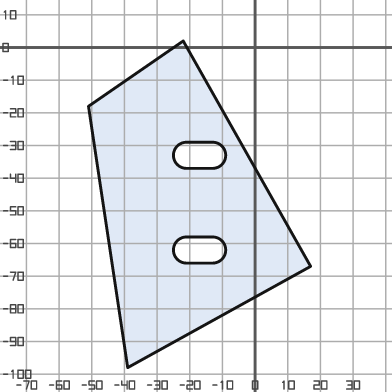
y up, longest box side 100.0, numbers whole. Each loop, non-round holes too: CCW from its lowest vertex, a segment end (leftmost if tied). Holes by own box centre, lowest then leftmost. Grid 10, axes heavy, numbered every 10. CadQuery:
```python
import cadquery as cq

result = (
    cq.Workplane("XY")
    .moveTo(-39.0, -98.0)
    .lineTo(17.0, -67.0)
    .lineTo(-22.0, 2.0)
    .lineTo(-51.0, -18.0)
    .close()
    .moveTo(-21.0, -66.0)
    .lineTo(-13.0, -66.0)
    .threePointArc((-9.0, -62.0), (-13.0, -58.0))
    .lineTo(-21.0, -58.0)
    .threePointArc((-25.0, -62.0), (-21.0, -66.0))
    .close()
    .moveTo(-21.0, -37.0)
    .lineTo(-13.0, -37.0)
    .threePointArc((-9.0, -33.0), (-13.0, -29.0))
    .lineTo(-21.0, -29.0)
    .threePointArc((-25.0, -33.0), (-21.0, -37.0))
    .close()
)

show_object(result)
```